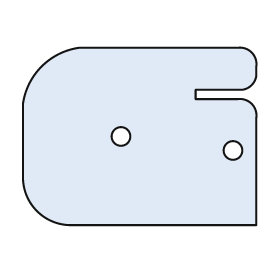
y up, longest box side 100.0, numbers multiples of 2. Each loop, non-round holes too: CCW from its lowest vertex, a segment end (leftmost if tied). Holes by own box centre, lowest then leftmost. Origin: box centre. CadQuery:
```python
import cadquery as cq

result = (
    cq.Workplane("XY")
    .moveTo(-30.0, -38.0)
    .lineTo(50.0, -38.0)
    .lineTo(50.0, 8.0)
    .threePointArc((48.0, 14.0), (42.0, 16.0))
    .lineTo(24.0, 16.0)
    .lineTo(24.0, 20.0)
    .lineTo(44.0, 20.0)
    .threePointArc((48.0, 22.0), (50.0, 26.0))
    .lineTo(50.0, 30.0)
    .threePointArc((48.0, 36.0), (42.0, 38.0))
    .lineTo(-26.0, 38.0)
    .threePointArc((-42.0, 30.0), (-50.0, 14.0))
    .lineTo(-50.0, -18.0)
    .threePointArc((-44.0, -32.0), (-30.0, -38.0))
    .close()
    .moveTo(40.0, -6.0)
    .circle(4.0)
    .moveTo(-8.0, 0.0)
    .circle(4.0)
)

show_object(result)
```